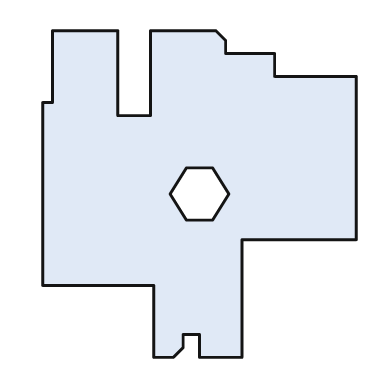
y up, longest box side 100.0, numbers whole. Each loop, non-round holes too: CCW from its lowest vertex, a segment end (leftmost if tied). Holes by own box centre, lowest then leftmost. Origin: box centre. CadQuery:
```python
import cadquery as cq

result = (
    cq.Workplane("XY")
    .moveTo(-14.0, -50.0)
    .lineTo(-8.0, -50.0)
    .lineTo(-5.0, -47.0)
    .lineTo(-5.0, -43.0)
    .lineTo(0.0, -43.0)
    .lineTo(0.0, -50.0)
    .lineTo(13.0, -50.0)
    .lineTo(13.0, -14.0)
    .lineTo(48.0, -14.0)
    .lineTo(48.0, 36.0)
    .lineTo(23.0, 36.0)
    .lineTo(23.0, 43.0)
    .lineTo(8.0, 43.0)
    .lineTo(8.0, 47.0)
    .lineTo(5.0, 50.0)
    .lineTo(-15.0, 50.0)
    .lineTo(-15.0, 24.0)
    .lineTo(-25.0, 24.0)
    .lineTo(-25.0, 50.0)
    .lineTo(-45.0, 50.0)
    .lineTo(-45.0, 28.0)
    .lineTo(-48.0, 28.0)
    .lineTo(-48.0, -28.0)
    .lineTo(-14.0, -28.0)
    .close()
    .moveTo(-4.0, -8.0)
    .lineTo(4.0, -8.0)
    .lineTo(9.0, 0.0)
    .lineTo(4.0, 8.0)
    .lineTo(-4.0, 8.0)
    .lineTo(-9.0, 0.0)
    .close()
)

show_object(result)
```